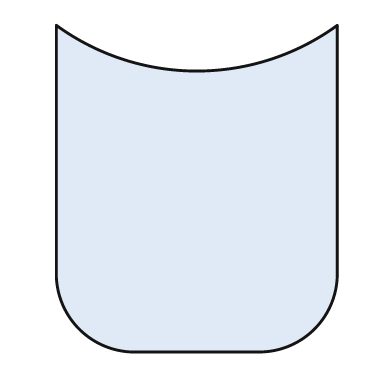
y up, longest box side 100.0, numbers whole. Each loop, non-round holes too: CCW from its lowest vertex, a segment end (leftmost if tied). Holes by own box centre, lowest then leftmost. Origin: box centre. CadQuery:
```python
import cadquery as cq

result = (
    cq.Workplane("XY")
    .moveTo(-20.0, -50.0)
    .lineTo(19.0, -50.0)
    .threePointArc((36.0, -43.0), (43.0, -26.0))
    .lineTo(43.0, 50.0)
    .threePointArc((0.0, 36.0), (-43.0, 50.0))
    .lineTo(-43.0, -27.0)
    .threePointArc((-36.0, -43.0), (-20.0, -50.0))
    .close()
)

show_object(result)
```